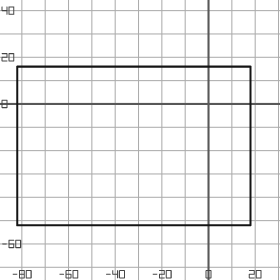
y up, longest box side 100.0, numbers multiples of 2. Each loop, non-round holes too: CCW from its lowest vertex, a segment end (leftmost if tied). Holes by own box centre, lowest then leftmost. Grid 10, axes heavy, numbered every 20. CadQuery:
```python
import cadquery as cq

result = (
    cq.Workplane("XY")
    .moveTo(-82.0, -52.0)
    .lineTo(18.0, -52.0)
    .lineTo(18.0, 16.0)
    .lineTo(-82.0, 16.0)
    .close()
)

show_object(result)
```